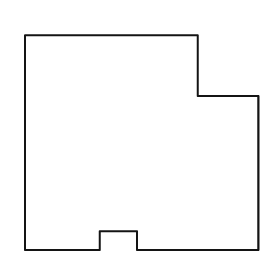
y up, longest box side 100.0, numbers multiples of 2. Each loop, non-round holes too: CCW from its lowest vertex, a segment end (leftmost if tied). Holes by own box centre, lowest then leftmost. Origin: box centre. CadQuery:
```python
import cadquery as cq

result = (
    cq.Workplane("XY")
    .moveTo(-50.0, -46.0)
    .lineTo(-18.0, -46.0)
    .lineTo(-18.0, -38.0)
    .lineTo(-2.0, -38.0)
    .lineTo(-2.0, -46.0)
    .lineTo(50.0, -46.0)
    .lineTo(50.0, 20.0)
    .lineTo(24.0, 20.0)
    .lineTo(24.0, 46.0)
    .lineTo(-50.0, 46.0)
    .close()
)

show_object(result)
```